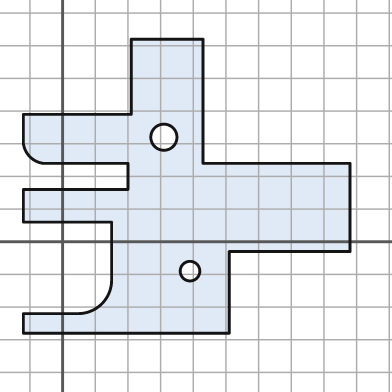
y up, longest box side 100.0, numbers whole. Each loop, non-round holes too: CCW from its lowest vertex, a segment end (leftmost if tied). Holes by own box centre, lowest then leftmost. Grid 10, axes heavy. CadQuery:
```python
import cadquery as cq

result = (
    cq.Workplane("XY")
    .moveTo(-12.0, -28.0)
    .lineTo(51.0, -28.0)
    .lineTo(51.0, -3.0)
    .lineTo(88.0, -3.0)
    .lineTo(88.0, 24.0)
    .lineTo(43.0, 24.0)
    .lineTo(43.0, 62.0)
    .lineTo(21.0, 62.0)
    .lineTo(21.0, 39.0)
    .lineTo(-12.0, 39.0)
    .lineTo(-12.0, 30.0)
    .threePointArc((-10.0, 26.0), (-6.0, 24.0))
    .lineTo(20.0, 24.0)
    .lineTo(20.0, 16.0)
    .lineTo(-12.0, 16.0)
    .lineTo(-12.0, 6.0)
    .lineTo(15.0, 6.0)
    .lineTo(15.0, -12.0)
    .threePointArc((12.0, -19.0), (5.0, -22.0))
    .lineTo(-12.0, -22.0)
    .close()
    .moveTo(39.0, -9.0)
    .circle(3.0)
    .moveTo(31.0, 32.0)
    .circle(4.0)
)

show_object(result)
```